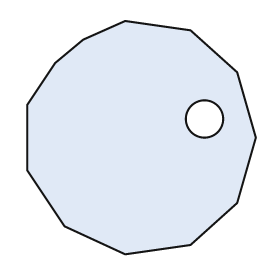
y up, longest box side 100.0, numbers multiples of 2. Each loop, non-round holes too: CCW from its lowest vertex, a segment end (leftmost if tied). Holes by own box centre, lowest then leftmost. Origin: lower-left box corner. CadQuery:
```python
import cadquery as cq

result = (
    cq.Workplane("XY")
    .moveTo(42.0, 0.0)
    .lineTo(70.0, 4.0)
    .lineTo(90.0, 22.0)
    .lineTo(98.0, 50.0)
    .lineTo(90.0, 78.0)
    .lineTo(70.0, 96.0)
    .lineTo(42.0, 100.0)
    .lineTo(24.0, 92.0)
    .lineTo(12.0, 82.0)
    .lineTo(0.0, 64.0)
    .lineTo(0.0, 36.0)
    .lineTo(16.0, 12.0)
    .close()
    .moveTo(76.0, 58.0)
    .circle(8.0)
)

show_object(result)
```